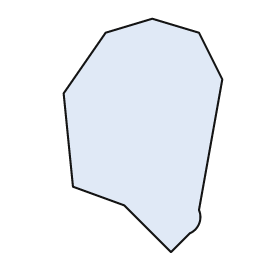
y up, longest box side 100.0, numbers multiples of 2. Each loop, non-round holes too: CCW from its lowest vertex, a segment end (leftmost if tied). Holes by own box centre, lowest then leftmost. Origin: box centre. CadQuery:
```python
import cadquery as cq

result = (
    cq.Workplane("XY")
    .moveTo(12.0, -50.0)
    .lineTo(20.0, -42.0)
    .threePointArc((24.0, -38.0), (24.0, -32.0))
    .lineTo(34.0, 24.0)
    .lineTo(24.0, 44.0)
    .lineTo(4.0, 50.0)
    .lineTo(-16.0, 44.0)
    .lineTo(-34.0, 18.0)
    .lineTo(-30.0, -22.0)
    .lineTo(-8.0, -30.0)
    .close()
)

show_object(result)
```